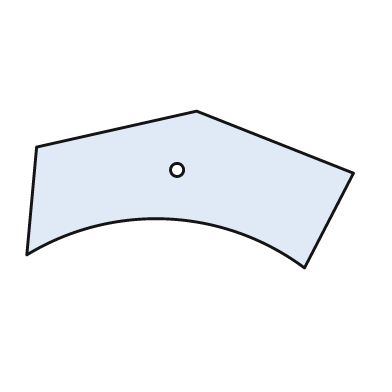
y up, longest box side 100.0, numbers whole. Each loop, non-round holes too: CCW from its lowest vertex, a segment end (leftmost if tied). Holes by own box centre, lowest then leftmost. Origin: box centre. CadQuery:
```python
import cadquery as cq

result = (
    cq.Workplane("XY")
    .moveTo(35.0, -24.0)
    .lineTo(50.0, 5.0)
    .lineTo(2.0, 24.0)
    .lineTo(-47.0, 13.0)
    .lineTo(-50.0, -20.0)
    .threePointArc((-7.0, -9.0), (35.0, -24.0))
    .close()
    .moveTo(-4.0, 6.0)
    .circle(2.0)
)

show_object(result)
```